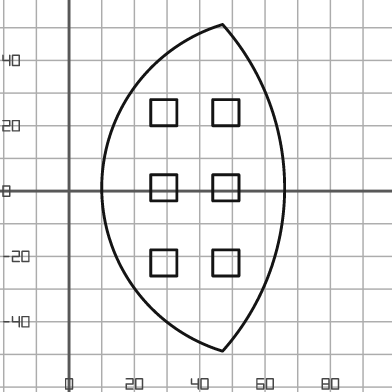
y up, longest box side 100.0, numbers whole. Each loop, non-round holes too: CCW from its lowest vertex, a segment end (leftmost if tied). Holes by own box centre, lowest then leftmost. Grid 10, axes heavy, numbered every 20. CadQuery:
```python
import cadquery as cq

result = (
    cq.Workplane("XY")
    .moveTo(47.0, -49.0)
    .threePointArc((66.0, 1.0), (47.0, 51.0))
    .threePointArc((10.0, 1.0), (47.0, -49.0))
    .close()
    .moveTo(25.0, -26.0)
    .lineTo(33.0, -26.0)
    .lineTo(33.0, -18.0)
    .lineTo(25.0, -18.0)
    .close()
    .moveTo(44.0, -26.0)
    .lineTo(52.0, -26.0)
    .lineTo(52.0, -18.0)
    .lineTo(44.0, -18.0)
    .close()
    .moveTo(25.0, -3.0)
    .lineTo(33.0, -3.0)
    .lineTo(33.0, 5.0)
    .lineTo(25.0, 5.0)
    .close()
    .moveTo(44.0, -3.0)
    .lineTo(52.0, -3.0)
    .lineTo(52.0, 5.0)
    .lineTo(44.0, 5.0)
    .close()
    .moveTo(25.0, 20.0)
    .lineTo(33.0, 20.0)
    .lineTo(33.0, 28.0)
    .lineTo(25.0, 28.0)
    .close()
    .moveTo(44.0, 20.0)
    .lineTo(52.0, 20.0)
    .lineTo(52.0, 28.0)
    .lineTo(44.0, 28.0)
    .close()
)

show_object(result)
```